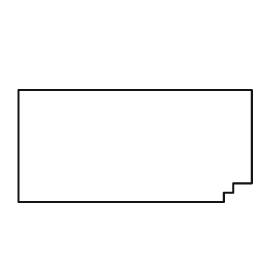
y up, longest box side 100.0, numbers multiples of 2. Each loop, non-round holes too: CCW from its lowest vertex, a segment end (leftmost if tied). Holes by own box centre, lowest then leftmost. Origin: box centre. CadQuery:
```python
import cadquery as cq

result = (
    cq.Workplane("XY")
    .moveTo(-50.0, -24.0)
    .lineTo(38.0, -24.0)
    .lineTo(38.0, -20.0)
    .lineTo(42.0, -20.0)
    .lineTo(42.0, -16.0)
    .lineTo(50.0, -16.0)
    .lineTo(50.0, 24.0)
    .lineTo(-50.0, 24.0)
    .close()
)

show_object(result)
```